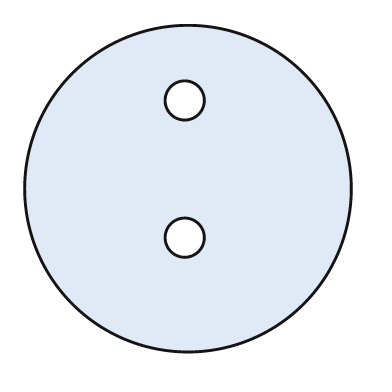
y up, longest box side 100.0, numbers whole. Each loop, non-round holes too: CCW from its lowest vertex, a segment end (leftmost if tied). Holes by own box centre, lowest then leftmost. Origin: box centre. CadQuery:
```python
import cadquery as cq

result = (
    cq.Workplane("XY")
    .moveTo(0.0, 0.0)
    .circle(50.0)
    .moveTo(-1.0, -15.0)
    .circle(6.0)
    .moveTo(-1.0, 27.0)
    .circle(6.0)
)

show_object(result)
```